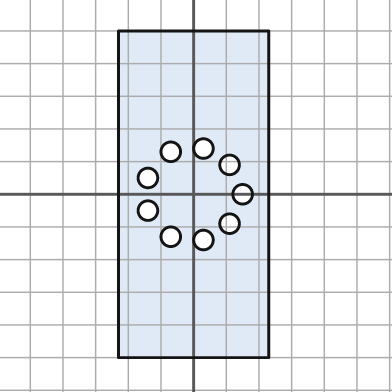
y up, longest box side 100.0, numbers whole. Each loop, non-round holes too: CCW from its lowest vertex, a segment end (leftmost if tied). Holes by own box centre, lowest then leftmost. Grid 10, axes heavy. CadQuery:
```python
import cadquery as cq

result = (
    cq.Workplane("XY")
    .moveTo(-23.0, -50.0)
    .lineTo(23.0, -50.0)
    .lineTo(23.0, 50.0)
    .lineTo(-23.0, 50.0)
    .close()
    .moveTo(3.0, -14.0)
    .circle(3.0)
    .moveTo(-7.0, -13.0)
    .circle(3.0)
    .moveTo(11.0, -9.0)
    .circle(3.0)
    .moveTo(-14.0, -5.0)
    .circle(3.0)
    .moveTo(15.0, 0.0)
    .circle(3.0)
    .moveTo(-14.0, 5.0)
    .circle(3.0)
    .moveTo(11.0, 9.0)
    .circle(3.0)
    .moveTo(-7.0, 13.0)
    .circle(3.0)
    .moveTo(3.0, 14.0)
    .circle(3.0)
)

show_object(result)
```